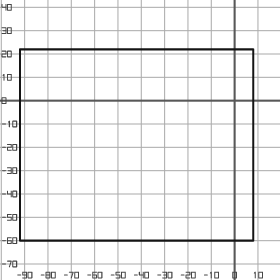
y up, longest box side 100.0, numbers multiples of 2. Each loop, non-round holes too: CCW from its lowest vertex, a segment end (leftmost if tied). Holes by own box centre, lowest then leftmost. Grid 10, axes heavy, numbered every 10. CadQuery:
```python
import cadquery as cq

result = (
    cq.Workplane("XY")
    .moveTo(-92.0, -60.0)
    .lineTo(8.0, -60.0)
    .lineTo(8.0, 22.0)
    .lineTo(-92.0, 22.0)
    .close()
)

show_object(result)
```